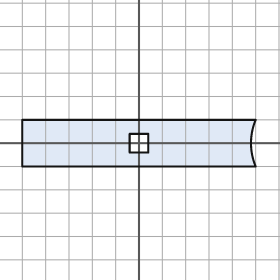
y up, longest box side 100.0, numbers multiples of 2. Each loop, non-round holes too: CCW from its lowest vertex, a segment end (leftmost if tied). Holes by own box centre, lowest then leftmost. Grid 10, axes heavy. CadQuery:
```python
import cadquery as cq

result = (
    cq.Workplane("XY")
    .moveTo(-50.0, -10.0)
    .lineTo(50.0, -10.0)
    .threePointArc((48.0, 0.0), (50.0, 10.0))
    .lineTo(-50.0, 10.0)
    .close()
    .moveTo(-4.0, -4.0)
    .lineTo(4.0, -4.0)
    .lineTo(4.0, 4.0)
    .lineTo(-4.0, 4.0)
    .close()
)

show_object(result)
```